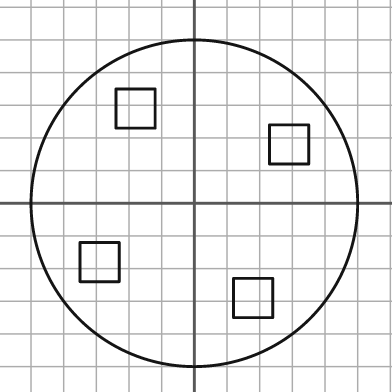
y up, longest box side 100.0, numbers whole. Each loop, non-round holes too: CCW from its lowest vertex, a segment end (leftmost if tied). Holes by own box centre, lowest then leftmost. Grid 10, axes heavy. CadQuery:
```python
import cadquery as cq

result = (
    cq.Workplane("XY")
    .moveTo(0.0, 0.0)
    .circle(50.0)
    .moveTo(12.0, -35.0)
    .lineTo(24.0, -35.0)
    .lineTo(24.0, -23.0)
    .lineTo(12.0, -23.0)
    .close()
    .moveTo(-35.0, -24.0)
    .lineTo(-23.0, -24.0)
    .lineTo(-23.0, -12.0)
    .lineTo(-35.0, -12.0)
    .close()
    .moveTo(23.0, 12.0)
    .lineTo(35.0, 12.0)
    .lineTo(35.0, 24.0)
    .lineTo(23.0, 24.0)
    .close()
    .moveTo(-24.0, 23.0)
    .lineTo(-12.0, 23.0)
    .lineTo(-12.0, 35.0)
    .lineTo(-24.0, 35.0)
    .close()
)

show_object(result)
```